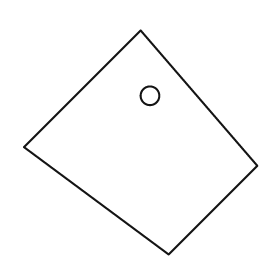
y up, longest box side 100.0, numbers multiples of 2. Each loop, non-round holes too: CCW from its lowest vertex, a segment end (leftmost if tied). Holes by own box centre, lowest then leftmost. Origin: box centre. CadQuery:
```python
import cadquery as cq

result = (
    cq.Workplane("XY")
    .moveTo(12.0, -48.0)
    .lineTo(50.0, -10.0)
    .lineTo(0.0, 48.0)
    .lineTo(-50.0, -2.0)
    .close()
    .moveTo(4.0, 20.0)
    .circle(4.0)
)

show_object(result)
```